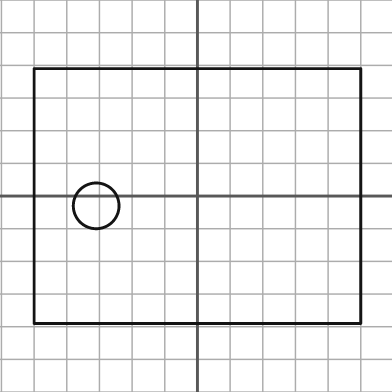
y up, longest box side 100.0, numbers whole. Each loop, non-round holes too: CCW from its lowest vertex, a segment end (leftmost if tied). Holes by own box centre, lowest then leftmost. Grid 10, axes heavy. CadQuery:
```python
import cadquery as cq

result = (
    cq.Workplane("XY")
    .moveTo(-50.0, -39.0)
    .lineTo(50.0, -39.0)
    .lineTo(50.0, 39.0)
    .lineTo(-50.0, 39.0)
    .close()
    .moveTo(-31.0, -3.0)
    .circle(7.0)
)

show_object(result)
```